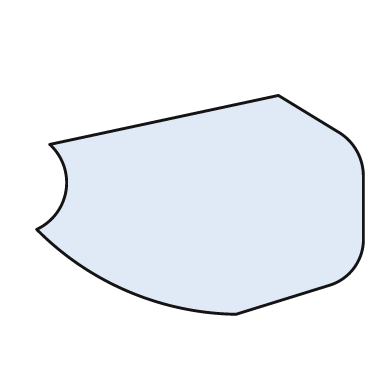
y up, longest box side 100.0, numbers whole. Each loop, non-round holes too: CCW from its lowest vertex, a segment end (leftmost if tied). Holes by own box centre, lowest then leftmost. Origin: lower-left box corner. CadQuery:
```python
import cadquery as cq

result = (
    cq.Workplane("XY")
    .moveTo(61.0, 0.0)
    .lineTo(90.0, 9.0)
    .threePointArc((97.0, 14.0), (100.0, 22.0))
    .lineTo(100.0, 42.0)
    .threePointArc((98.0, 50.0), (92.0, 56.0))
    .lineTo(74.0, 67.0)
    .lineTo(4.0, 52.0)
    .threePointArc((9.0, 38.0), (0.0, 26.0))
    .threePointArc((28.0, 7.0), (61.0, 0.0))
    .close()
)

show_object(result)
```